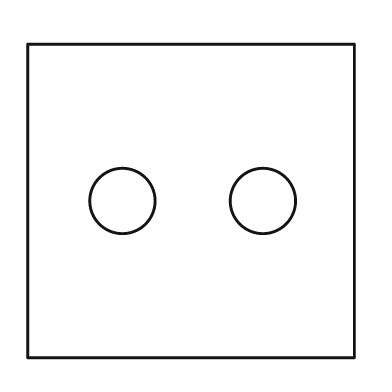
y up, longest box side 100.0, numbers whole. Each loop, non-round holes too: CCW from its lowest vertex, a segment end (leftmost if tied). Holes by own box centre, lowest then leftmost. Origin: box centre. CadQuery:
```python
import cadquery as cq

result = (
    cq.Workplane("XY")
    .moveTo(-50.0, -48.0)
    .lineTo(50.0, -48.0)
    .lineTo(50.0, 48.0)
    .lineTo(-50.0, 48.0)
    .close()
    .moveTo(-21.0, 0.0)
    .circle(10.0)
    .moveTo(22.0, 0.0)
    .circle(10.0)
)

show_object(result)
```